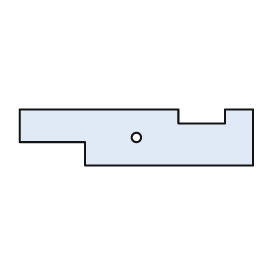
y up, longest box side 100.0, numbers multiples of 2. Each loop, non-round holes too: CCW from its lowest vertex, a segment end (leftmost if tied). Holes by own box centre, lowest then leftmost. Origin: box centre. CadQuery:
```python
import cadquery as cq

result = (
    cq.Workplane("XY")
    .moveTo(-22.0, -12.0)
    .lineTo(50.0, -12.0)
    .lineTo(50.0, 12.0)
    .lineTo(38.0, 12.0)
    .lineTo(38.0, 6.0)
    .lineTo(18.0, 6.0)
    .lineTo(18.0, 12.0)
    .lineTo(-50.0, 12.0)
    .lineTo(-50.0, -2.0)
    .lineTo(-22.0, -2.0)
    .close()
    .moveTo(0.0, 0.0)
    .circle(2.0)
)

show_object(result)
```